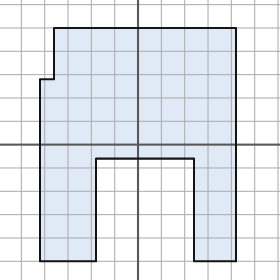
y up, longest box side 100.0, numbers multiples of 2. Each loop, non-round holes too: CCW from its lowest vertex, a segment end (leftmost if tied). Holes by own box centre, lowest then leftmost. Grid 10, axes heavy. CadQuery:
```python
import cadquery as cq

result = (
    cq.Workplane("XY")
    .moveTo(-42.0, -50.0)
    .lineTo(-18.0, -50.0)
    .lineTo(-18.0, -6.0)
    .lineTo(24.0, -6.0)
    .lineTo(24.0, -50.0)
    .lineTo(42.0, -50.0)
    .lineTo(42.0, 50.0)
    .lineTo(-36.0, 50.0)
    .lineTo(-36.0, 28.0)
    .lineTo(-42.0, 28.0)
    .close()
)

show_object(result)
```